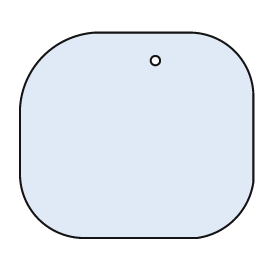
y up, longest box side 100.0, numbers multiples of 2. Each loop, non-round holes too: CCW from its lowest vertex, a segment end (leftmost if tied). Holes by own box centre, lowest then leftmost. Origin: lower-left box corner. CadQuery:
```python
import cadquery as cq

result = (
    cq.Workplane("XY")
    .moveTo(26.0, 0.0)
    .lineTo(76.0, 0.0)
    .threePointArc((92.0, 8.0), (100.0, 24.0))
    .lineTo(100.0, 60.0)
    .threePointArc((92.0, 80.0), (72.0, 88.0))
    .lineTo(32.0, 88.0)
    .threePointArc((10.0, 78.0), (0.0, 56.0))
    .lineTo(0.0, 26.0)
    .threePointArc((8.0, 8.0), (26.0, 0.0))
    .close()
    .moveTo(58.0, 76.0)
    .circle(2.0)
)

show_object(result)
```